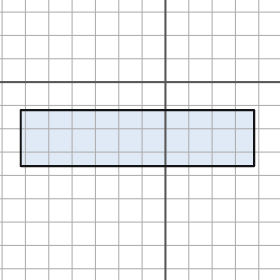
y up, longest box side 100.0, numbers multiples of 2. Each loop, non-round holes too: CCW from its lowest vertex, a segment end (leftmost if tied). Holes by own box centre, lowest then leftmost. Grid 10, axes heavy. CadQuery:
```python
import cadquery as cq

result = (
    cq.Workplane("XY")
    .moveTo(-62.0, -36.0)
    .lineTo(38.0, -36.0)
    .lineTo(38.0, -12.0)
    .lineTo(-62.0, -12.0)
    .close()
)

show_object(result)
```